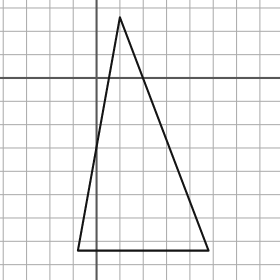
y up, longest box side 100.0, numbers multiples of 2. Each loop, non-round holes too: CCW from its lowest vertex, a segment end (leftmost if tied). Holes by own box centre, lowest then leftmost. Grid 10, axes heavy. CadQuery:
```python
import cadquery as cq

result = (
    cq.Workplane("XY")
    .moveTo(-8.0, -74.0)
    .lineTo(48.0, -74.0)
    .lineTo(10.0, 26.0)
    .close()
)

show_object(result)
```